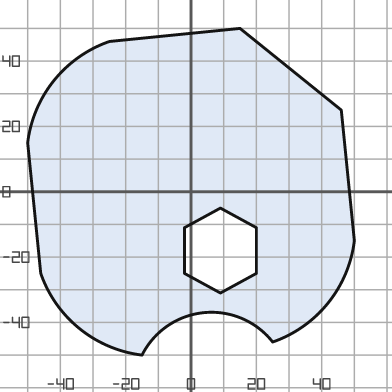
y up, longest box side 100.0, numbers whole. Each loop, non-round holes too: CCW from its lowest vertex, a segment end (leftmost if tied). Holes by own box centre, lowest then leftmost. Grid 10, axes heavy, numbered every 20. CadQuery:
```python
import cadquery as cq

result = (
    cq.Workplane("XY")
    .moveTo(-15.0, -50.0)
    .threePointArc((4.0, -37.0), (25.0, -46.0))
    .threePointArc((42.0, -34.0), (50.0, -15.0))
    .lineTo(46.0, 25.0)
    .lineTo(15.0, 50.0)
    .lineTo(-25.0, 46.0)
    .threePointArc((-42.0, 34.0), (-50.0, 15.0))
    .lineTo(-46.0, -25.0)
    .threePointArc((-34.0, -42.0), (-15.0, -50.0))
    .close()
    .moveTo(9.0, -31.0)
    .lineTo(20.0, -25.0)
    .lineTo(20.0, -11.0)
    .lineTo(9.0, -5.0)
    .lineTo(-2.0, -11.0)
    .lineTo(-2.0, -25.0)
    .close()
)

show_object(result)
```